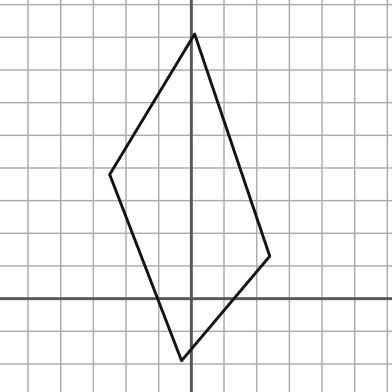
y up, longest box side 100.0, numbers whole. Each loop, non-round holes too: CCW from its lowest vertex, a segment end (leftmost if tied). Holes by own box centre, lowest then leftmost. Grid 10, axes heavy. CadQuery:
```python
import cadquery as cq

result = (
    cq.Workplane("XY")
    .moveTo(-3.0, -19.0)
    .lineTo(24.0, 13.0)
    .lineTo(1.0, 81.0)
    .lineTo(-25.0, 38.0)
    .close()
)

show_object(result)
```